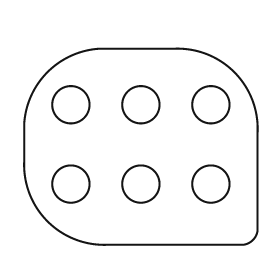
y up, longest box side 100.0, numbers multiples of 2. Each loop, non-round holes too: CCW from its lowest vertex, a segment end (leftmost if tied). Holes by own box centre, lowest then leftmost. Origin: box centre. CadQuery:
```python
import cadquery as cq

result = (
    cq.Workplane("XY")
    .moveTo(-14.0, -42.0)
    .lineTo(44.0, -42.0)
    .threePointArc((48.0, -40.0), (50.0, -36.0))
    .lineTo(50.0, 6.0)
    .threePointArc((40.0, 32.0), (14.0, 42.0))
    .lineTo(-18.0, 42.0)
    .threePointArc((-40.0, 32.0), (-50.0, 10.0))
    .lineTo(-50.0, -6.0)
    .threePointArc((-40.0, -32.0), (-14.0, -42.0))
    .close()
    .moveTo(-30.0, -16.0)
    .circle(8.0)
    .moveTo(0.0, -16.0)
    .circle(8.0)
    .moveTo(30.0, -16.0)
    .circle(8.0)
    .moveTo(-30.0, 18.0)
    .circle(8.0)
    .moveTo(0.0, 18.0)
    .circle(8.0)
    .moveTo(30.0, 18.0)
    .circle(8.0)
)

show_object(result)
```